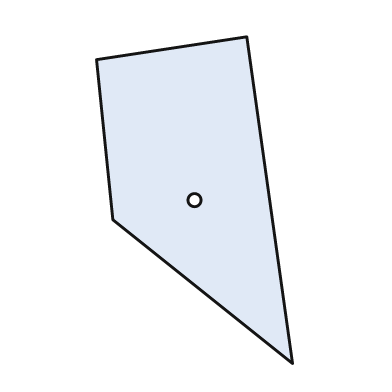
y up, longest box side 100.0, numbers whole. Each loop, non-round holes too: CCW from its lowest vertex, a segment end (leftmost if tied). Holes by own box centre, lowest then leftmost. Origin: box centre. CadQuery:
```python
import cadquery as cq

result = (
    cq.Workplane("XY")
    .moveTo(30.0, -50.0)
    .lineTo(16.0, 50.0)
    .lineTo(-30.0, 43.0)
    .lineTo(-25.0, -6.0)
    .close()
    .moveTo(0.0, 0.0)
    .circle(2.0)
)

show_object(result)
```